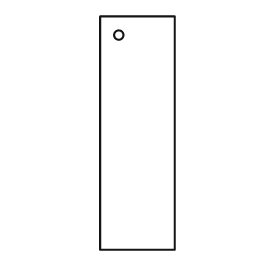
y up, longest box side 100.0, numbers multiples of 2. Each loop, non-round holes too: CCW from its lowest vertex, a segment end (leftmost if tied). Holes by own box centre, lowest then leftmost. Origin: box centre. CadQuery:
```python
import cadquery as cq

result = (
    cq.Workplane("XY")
    .moveTo(-16.0, -50.0)
    .lineTo(16.0, -50.0)
    .lineTo(16.0, 50.0)
    .lineTo(-16.0, 50.0)
    .close()
    .moveTo(-8.0, 42.0)
    .circle(2.0)
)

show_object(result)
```